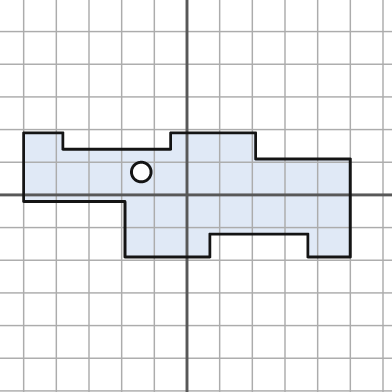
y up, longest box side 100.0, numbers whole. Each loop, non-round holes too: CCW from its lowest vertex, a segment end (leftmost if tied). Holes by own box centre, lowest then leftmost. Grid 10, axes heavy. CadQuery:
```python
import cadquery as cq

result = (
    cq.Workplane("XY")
    .moveTo(-19.0, -19.0)
    .lineTo(7.0, -19.0)
    .lineTo(7.0, -12.0)
    .lineTo(37.0, -12.0)
    .lineTo(37.0, -19.0)
    .lineTo(50.0, -19.0)
    .lineTo(50.0, 11.0)
    .lineTo(21.0, 11.0)
    .lineTo(21.0, 19.0)
    .lineTo(-5.0, 19.0)
    .lineTo(-5.0, 14.0)
    .lineTo(-38.0, 14.0)
    .lineTo(-38.0, 19.0)
    .lineTo(-50.0, 19.0)
    .lineTo(-50.0, -2.0)
    .lineTo(-19.0, -2.0)
    .close()
    .moveTo(-14.0, 7.0)
    .circle(3.0)
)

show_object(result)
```